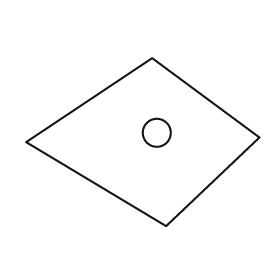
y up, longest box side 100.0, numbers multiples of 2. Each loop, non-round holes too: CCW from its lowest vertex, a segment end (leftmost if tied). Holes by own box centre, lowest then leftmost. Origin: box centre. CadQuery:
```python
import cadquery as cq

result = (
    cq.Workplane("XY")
    .moveTo(10.0, -36.0)
    .lineTo(50.0, 2.0)
    .lineTo(4.0, 36.0)
    .lineTo(-50.0, 0.0)
    .close()
    .moveTo(6.0, 4.0)
    .circle(6.0)
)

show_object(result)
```